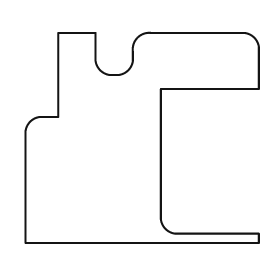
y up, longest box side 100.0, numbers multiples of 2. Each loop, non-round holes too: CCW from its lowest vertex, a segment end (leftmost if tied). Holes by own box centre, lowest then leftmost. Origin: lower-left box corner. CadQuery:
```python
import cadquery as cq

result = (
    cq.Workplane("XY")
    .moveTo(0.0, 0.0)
    .lineTo(100.0, 0.0)
    .lineTo(100.0, 4.0)
    .lineTo(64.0, 4.0)
    .threePointArc((60.0, 6.0), (58.0, 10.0))
    .lineTo(58.0, 66.0)
    .lineTo(100.0, 66.0)
    .lineTo(100.0, 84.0)
    .threePointArc((98.0, 88.0), (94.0, 90.0))
    .lineTo(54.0, 90.0)
    .threePointArc((48.0, 88.0), (46.0, 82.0))
    .lineTo(46.0, 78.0)
    .threePointArc((44.0, 74.0), (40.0, 72.0))
    .lineTo(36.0, 72.0)
    .threePointArc((32.0, 74.0), (30.0, 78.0))
    .lineTo(30.0, 90.0)
    .lineTo(14.0, 90.0)
    .lineTo(14.0, 54.0)
    .lineTo(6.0, 54.0)
    .threePointArc((2.0, 52.0), (0.0, 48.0))
    .close()
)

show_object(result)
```